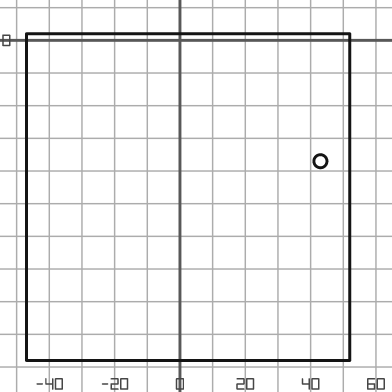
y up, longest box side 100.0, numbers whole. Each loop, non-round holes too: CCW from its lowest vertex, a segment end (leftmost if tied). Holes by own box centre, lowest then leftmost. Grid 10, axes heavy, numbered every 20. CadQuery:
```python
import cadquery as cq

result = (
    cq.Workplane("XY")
    .moveTo(-47.0, -98.0)
    .lineTo(52.0, -98.0)
    .lineTo(52.0, 2.0)
    .lineTo(-47.0, 2.0)
    .close()
    .moveTo(43.0, -37.0)
    .circle(2.0)
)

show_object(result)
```